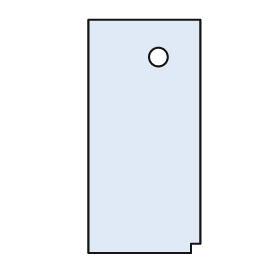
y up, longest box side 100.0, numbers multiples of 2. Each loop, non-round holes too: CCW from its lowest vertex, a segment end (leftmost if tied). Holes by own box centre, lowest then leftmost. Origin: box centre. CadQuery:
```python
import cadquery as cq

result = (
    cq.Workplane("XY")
    .moveTo(-24.0, -50.0)
    .lineTo(20.0, -50.0)
    .lineTo(20.0, -46.0)
    .lineTo(24.0, -46.0)
    .lineTo(24.0, 50.0)
    .lineTo(-24.0, 50.0)
    .close()
    .moveTo(6.0, 34.0)
    .circle(4.0)
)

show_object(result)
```